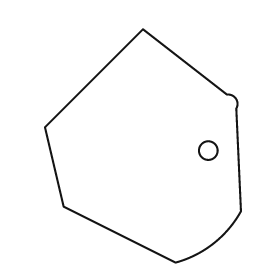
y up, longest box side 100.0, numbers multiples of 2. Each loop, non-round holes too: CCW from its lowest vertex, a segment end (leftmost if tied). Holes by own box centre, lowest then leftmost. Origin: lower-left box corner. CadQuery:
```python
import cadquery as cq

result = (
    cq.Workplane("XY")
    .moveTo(56.0, 0.0)
    .threePointArc((72.0, 8.0), (84.0, 22.0))
    .lineTo(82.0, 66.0)
    .threePointArc((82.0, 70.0), (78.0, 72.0))
    .lineTo(42.0, 100.0)
    .lineTo(0.0, 58.0)
    .lineTo(8.0, 24.0)
    .close()
    .moveTo(70.0, 48.0)
    .circle(4.0)
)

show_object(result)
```